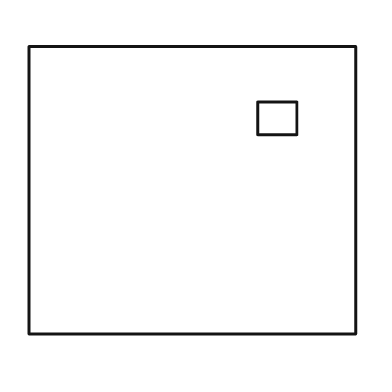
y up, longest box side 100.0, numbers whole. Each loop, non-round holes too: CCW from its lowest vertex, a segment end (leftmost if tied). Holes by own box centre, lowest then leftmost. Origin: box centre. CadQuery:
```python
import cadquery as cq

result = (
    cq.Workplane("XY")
    .moveTo(-50.0, -44.0)
    .lineTo(50.0, -44.0)
    .lineTo(50.0, 44.0)
    .lineTo(-50.0, 44.0)
    .close()
    .moveTo(20.0, 17.0)
    .lineTo(32.0, 17.0)
    .lineTo(32.0, 27.0)
    .lineTo(20.0, 27.0)
    .close()
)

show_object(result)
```